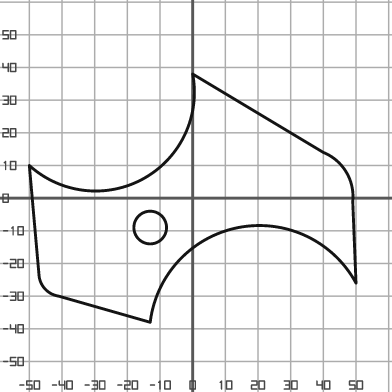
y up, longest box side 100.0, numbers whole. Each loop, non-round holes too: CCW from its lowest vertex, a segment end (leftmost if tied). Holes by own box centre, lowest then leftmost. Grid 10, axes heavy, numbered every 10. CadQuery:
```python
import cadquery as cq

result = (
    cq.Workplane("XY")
    .moveTo(-13.0, -38.0)
    .threePointArc((14.0, -9.0), (50.0, -26.0))
    .lineTo(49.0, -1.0)
    .threePointArc((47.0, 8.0), (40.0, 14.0))
    .lineTo(0.0, 38.0)
    .threePointArc((-15.0, 6.0), (-50.0, 10.0))
    .lineTo(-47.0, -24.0)
    .threePointArc((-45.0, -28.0), (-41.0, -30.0))
    .close()
    .moveTo(-13.0, -9.0)
    .circle(5.0)
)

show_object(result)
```